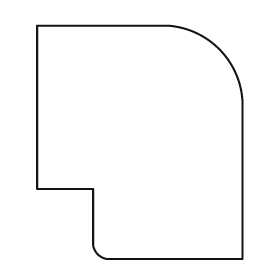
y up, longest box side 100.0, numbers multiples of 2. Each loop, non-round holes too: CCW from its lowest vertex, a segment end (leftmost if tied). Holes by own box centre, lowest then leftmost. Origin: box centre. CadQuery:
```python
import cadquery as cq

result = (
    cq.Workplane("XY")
    .moveTo(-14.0, -50.0)
    .lineTo(44.0, -50.0)
    .lineTo(44.0, 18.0)
    .threePointArc((34.0, 40.0), (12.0, 50.0))
    .lineTo(-44.0, 50.0)
    .lineTo(-44.0, -20.0)
    .lineTo(-20.0, -20.0)
    .lineTo(-20.0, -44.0)
    .threePointArc((-18.0, -48.0), (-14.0, -50.0))
    .close()
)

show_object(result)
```